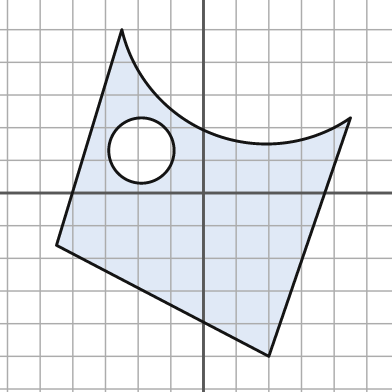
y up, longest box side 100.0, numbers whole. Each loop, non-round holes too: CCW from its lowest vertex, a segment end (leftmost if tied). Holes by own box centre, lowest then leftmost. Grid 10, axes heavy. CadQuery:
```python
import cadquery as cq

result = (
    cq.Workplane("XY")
    .moveTo(20.0, -50.0)
    .lineTo(45.0, 23.0)
    .threePointArc((3.0, 18.0), (-25.0, 50.0))
    .lineTo(-45.0, -16.0)
    .close()
    .moveTo(-19.0, 13.0)
    .circle(10.0)
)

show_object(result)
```